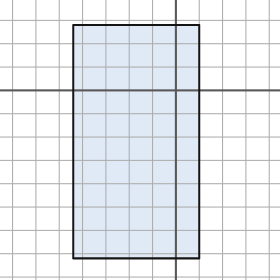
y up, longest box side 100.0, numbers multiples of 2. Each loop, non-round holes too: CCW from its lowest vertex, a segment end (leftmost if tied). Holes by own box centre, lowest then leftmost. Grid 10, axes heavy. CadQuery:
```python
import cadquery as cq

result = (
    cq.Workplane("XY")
    .moveTo(-44.0, -72.0)
    .lineTo(10.0, -72.0)
    .lineTo(10.0, 28.0)
    .lineTo(-44.0, 28.0)
    .close()
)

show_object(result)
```